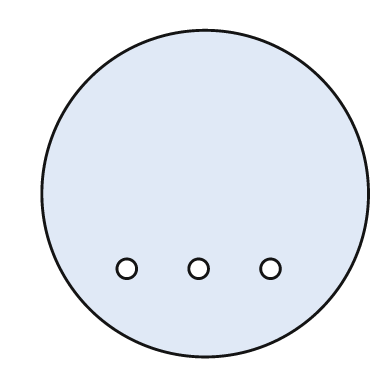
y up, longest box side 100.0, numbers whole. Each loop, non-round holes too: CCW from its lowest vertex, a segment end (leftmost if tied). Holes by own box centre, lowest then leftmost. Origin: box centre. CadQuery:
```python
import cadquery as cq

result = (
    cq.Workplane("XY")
    .moveTo(0.0, 0.0)
    .circle(50.0)
    .moveTo(-24.0, -23.0)
    .circle(3.0)
    .moveTo(-2.0, -23.0)
    .circle(3.0)
    .moveTo(20.0, -23.0)
    .circle(3.0)
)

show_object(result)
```